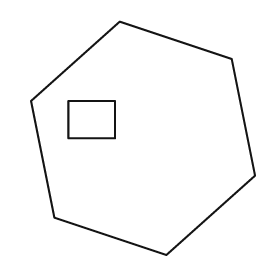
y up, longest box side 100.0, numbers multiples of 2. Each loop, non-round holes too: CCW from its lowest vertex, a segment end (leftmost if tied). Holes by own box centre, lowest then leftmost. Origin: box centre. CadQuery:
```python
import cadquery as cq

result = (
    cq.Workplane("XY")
    .moveTo(10.0, -50.0)
    .lineTo(48.0, -16.0)
    .lineTo(38.0, 34.0)
    .lineTo(-10.0, 50.0)
    .lineTo(-48.0, 16.0)
    .lineTo(-38.0, -34.0)
    .close()
    .moveTo(-32.0, 0.0)
    .lineTo(-12.0, 0.0)
    .lineTo(-12.0, 16.0)
    .lineTo(-32.0, 16.0)
    .close()
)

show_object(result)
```